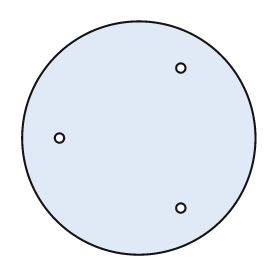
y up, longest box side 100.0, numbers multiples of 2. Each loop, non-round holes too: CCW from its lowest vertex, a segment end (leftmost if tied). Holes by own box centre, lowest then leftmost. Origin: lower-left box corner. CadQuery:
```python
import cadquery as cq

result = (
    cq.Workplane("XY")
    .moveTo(50.0, 50.0)
    .circle(50.0)
    .moveTo(68.0, 20.0)
    .circle(2.0)
    .moveTo(16.0, 50.0)
    .circle(2.0)
    .moveTo(68.0, 80.0)
    .circle(2.0)
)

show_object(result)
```